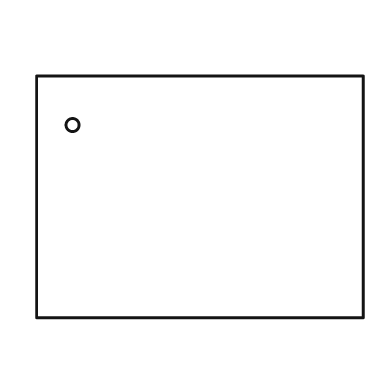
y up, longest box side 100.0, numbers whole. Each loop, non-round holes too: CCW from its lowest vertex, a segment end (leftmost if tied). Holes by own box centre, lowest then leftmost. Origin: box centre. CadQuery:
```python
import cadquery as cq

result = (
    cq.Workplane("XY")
    .moveTo(-50.0, -37.0)
    .lineTo(50.0, -37.0)
    .lineTo(50.0, 37.0)
    .lineTo(-50.0, 37.0)
    .close()
    .moveTo(-39.0, 22.0)
    .circle(2.0)
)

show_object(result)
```